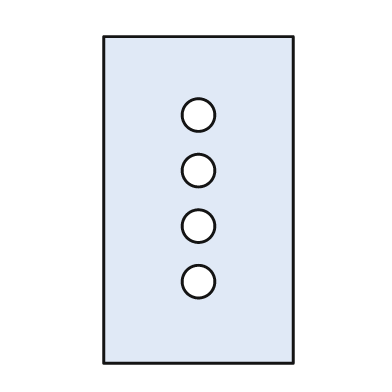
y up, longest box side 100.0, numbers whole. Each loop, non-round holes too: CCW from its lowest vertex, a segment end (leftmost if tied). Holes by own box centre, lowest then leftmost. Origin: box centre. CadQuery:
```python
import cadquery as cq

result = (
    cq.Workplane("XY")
    .moveTo(-29.0, -50.0)
    .lineTo(29.0, -50.0)
    .lineTo(29.0, 50.0)
    .lineTo(-29.0, 50.0)
    .close()
    .moveTo(0.0, -25.0)
    .circle(5.0)
    .moveTo(0.0, -8.0)
    .circle(5.0)
    .moveTo(0.0, 9.0)
    .circle(5.0)
    .moveTo(0.0, 26.0)
    .circle(5.0)
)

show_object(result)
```